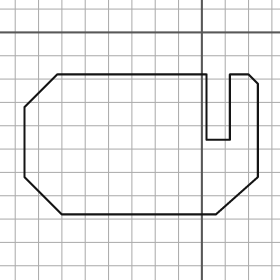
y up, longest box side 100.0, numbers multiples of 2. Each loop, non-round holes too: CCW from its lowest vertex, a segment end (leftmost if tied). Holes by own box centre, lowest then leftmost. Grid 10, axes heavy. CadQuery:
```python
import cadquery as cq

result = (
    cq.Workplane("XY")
    .moveTo(-60.0, -78.0)
    .lineTo(6.0, -78.0)
    .lineTo(24.0, -62.0)
    .lineTo(24.0, -22.0)
    .lineTo(20.0, -18.0)
    .lineTo(12.0, -18.0)
    .lineTo(12.0, -46.0)
    .lineTo(2.0, -46.0)
    .lineTo(2.0, -18.0)
    .lineTo(-62.0, -18.0)
    .lineTo(-76.0, -32.0)
    .lineTo(-76.0, -62.0)
    .close()
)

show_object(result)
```